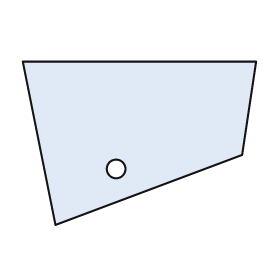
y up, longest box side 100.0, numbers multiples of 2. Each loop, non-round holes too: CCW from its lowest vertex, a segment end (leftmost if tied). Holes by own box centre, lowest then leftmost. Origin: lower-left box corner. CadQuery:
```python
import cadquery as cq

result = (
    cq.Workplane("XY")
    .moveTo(14.0, 0.0)
    .lineTo(94.0, 30.0)
    .lineTo(100.0, 70.0)
    .lineTo(0.0, 70.0)
    .close()
    .moveTo(40.0, 24.0)
    .circle(4.0)
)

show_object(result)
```